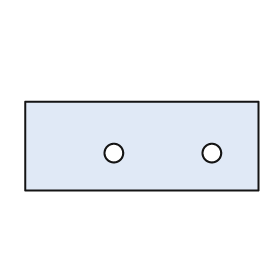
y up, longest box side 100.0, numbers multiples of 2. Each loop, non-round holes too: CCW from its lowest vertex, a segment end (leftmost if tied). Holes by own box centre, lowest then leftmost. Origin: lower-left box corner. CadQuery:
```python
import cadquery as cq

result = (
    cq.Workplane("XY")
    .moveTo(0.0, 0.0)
    .lineTo(100.0, 0.0)
    .lineTo(100.0, 38.0)
    .lineTo(0.0, 38.0)
    .close()
    .moveTo(38.0, 16.0)
    .circle(4.0)
    .moveTo(80.0, 16.0)
    .circle(4.0)
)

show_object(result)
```